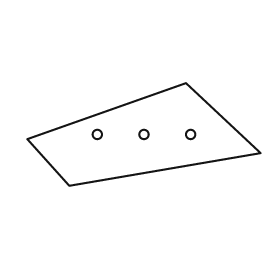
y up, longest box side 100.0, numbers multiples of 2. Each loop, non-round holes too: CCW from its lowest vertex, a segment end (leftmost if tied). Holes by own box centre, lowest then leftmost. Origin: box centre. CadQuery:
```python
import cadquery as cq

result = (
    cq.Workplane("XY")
    .moveTo(-32.0, -22.0)
    .lineTo(50.0, -8.0)
    .lineTo(18.0, 22.0)
    .lineTo(-50.0, -2.0)
    .close()
    .moveTo(-20.0, 0.0)
    .circle(2.0)
    .moveTo(0.0, 0.0)
    .circle(2.0)
    .moveTo(20.0, 0.0)
    .circle(2.0)
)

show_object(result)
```